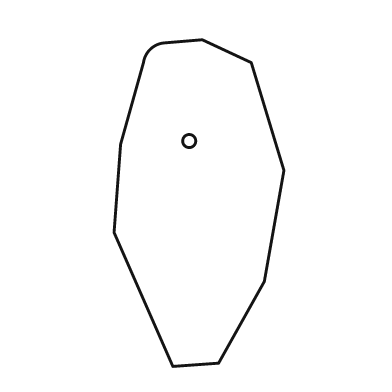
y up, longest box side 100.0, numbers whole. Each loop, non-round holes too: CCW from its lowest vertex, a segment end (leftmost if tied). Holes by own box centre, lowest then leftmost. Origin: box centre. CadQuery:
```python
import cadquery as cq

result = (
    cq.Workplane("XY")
    .moveTo(-8.0, -50.0)
    .lineTo(6.0, -49.0)
    .lineTo(20.0, -24.0)
    .lineTo(26.0, 10.0)
    .lineTo(16.0, 43.0)
    .lineTo(1.0, 50.0)
    .lineTo(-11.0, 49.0)
    .threePointArc((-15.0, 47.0), (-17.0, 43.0))
    .lineTo(-24.0, 18.0)
    .lineTo(-26.0, -9.0)
    .close()
    .moveTo(-3.0, 19.0)
    .circle(2.0)
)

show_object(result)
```